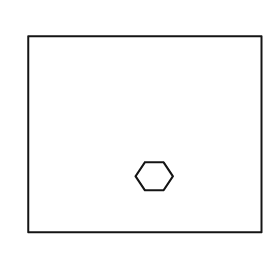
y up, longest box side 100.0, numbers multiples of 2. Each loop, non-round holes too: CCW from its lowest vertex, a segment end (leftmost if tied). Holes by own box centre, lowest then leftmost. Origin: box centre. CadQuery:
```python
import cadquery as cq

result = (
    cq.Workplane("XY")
    .moveTo(-50.0, -42.0)
    .lineTo(50.0, -42.0)
    .lineTo(50.0, 42.0)
    .lineTo(-50.0, 42.0)
    .close()
    .moveTo(0.0, -24.0)
    .lineTo(8.0, -24.0)
    .lineTo(12.0, -18.0)
    .lineTo(8.0, -12.0)
    .lineTo(0.0, -12.0)
    .lineTo(-4.0, -18.0)
    .close()
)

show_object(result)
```